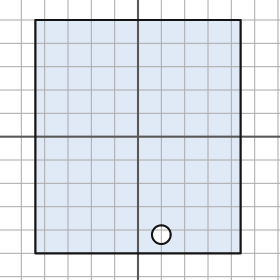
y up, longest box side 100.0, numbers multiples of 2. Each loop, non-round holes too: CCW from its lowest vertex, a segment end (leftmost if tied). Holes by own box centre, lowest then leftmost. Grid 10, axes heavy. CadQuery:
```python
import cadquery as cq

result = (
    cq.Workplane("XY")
    .moveTo(-44.0, -50.0)
    .lineTo(44.0, -50.0)
    .lineTo(44.0, 50.0)
    .lineTo(-44.0, 50.0)
    .close()
    .moveTo(10.0, -42.0)
    .circle(4.0)
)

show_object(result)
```